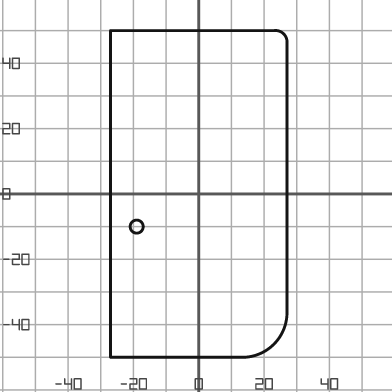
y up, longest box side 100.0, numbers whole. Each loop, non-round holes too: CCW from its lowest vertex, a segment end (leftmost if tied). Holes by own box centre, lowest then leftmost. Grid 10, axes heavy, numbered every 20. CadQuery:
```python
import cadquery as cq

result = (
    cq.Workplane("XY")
    .moveTo(-27.0, -50.0)
    .lineTo(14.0, -50.0)
    .threePointArc((23.0, -46.0), (27.0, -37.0))
    .lineTo(27.0, 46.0)
    .threePointArc((26.0, 49.0), (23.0, 50.0))
    .lineTo(-27.0, 50.0)
    .close()
    .moveTo(-19.0, -10.0)
    .circle(2.0)
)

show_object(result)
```